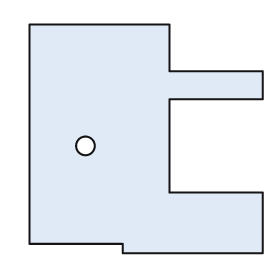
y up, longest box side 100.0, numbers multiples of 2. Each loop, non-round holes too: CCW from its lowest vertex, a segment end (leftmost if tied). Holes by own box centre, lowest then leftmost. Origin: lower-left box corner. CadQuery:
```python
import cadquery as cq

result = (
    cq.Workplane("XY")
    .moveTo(40.0, 0.0)
    .lineTo(100.0, 0.0)
    .lineTo(100.0, 26.0)
    .lineTo(60.0, 26.0)
    .lineTo(60.0, 66.0)
    .lineTo(100.0, 66.0)
    .lineTo(100.0, 78.0)
    .lineTo(60.0, 78.0)
    .lineTo(60.0, 98.0)
    .lineTo(0.0, 98.0)
    .lineTo(0.0, 4.0)
    .lineTo(40.0, 4.0)
    .close()
    .moveTo(24.0, 46.0)
    .circle(4.0)
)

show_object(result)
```